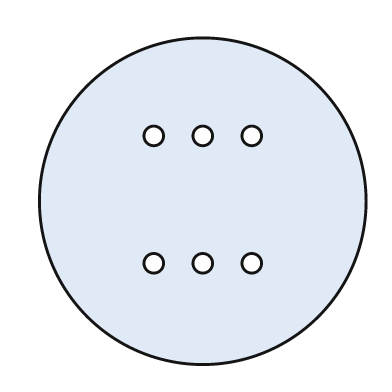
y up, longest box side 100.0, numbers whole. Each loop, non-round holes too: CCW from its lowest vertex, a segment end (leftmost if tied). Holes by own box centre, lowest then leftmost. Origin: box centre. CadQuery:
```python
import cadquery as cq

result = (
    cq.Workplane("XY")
    .moveTo(0.0, 0.0)
    .circle(50.0)
    .moveTo(-15.0, -19.0)
    .circle(3.0)
    .moveTo(0.0, -19.0)
    .circle(3.0)
    .moveTo(15.0, -19.0)
    .circle(3.0)
    .moveTo(-15.0, 20.0)
    .circle(3.0)
    .moveTo(0.0, 20.0)
    .circle(3.0)
    .moveTo(15.0, 20.0)
    .circle(3.0)
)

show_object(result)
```